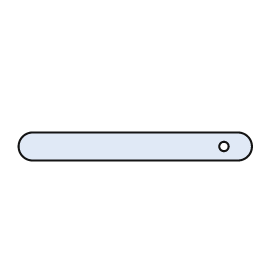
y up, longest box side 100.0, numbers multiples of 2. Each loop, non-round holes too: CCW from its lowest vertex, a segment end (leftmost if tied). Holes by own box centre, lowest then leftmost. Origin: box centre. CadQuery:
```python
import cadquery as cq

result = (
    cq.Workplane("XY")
    .moveTo(-44.0, -6.0)
    .lineTo(44.0, -6.0)
    .threePointArc((50.0, 0.0), (44.0, 6.0))
    .lineTo(-44.0, 6.0)
    .threePointArc((-50.0, 0.0), (-44.0, -6.0))
    .close()
    .moveTo(38.0, 0.0)
    .circle(2.0)
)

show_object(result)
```